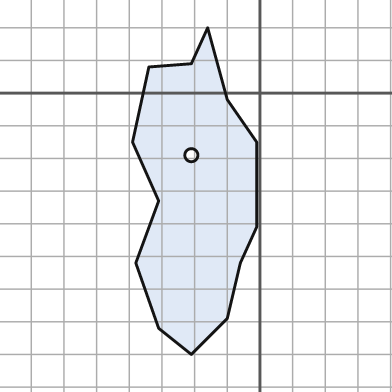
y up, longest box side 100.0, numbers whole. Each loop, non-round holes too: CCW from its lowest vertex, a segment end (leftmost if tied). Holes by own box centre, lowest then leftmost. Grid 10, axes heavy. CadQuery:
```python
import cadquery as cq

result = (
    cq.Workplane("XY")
    .moveTo(-21.0, -80.0)
    .lineTo(-10.0, -69.0)
    .lineTo(-6.0, -52.0)
    .lineTo(-1.0, -41.0)
    .lineTo(-1.0, -15.0)
    .lineTo(-10.0, -2.0)
    .lineTo(-16.0, 20.0)
    .lineTo(-21.0, 9.0)
    .lineTo(-34.0, 8.0)
    .lineTo(-39.0, -15.0)
    .lineTo(-31.0, -33.0)
    .lineTo(-38.0, -52.0)
    .lineTo(-31.0, -72.0)
    .close()
    .moveTo(-21.0, -19.0)
    .circle(2.0)
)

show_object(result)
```